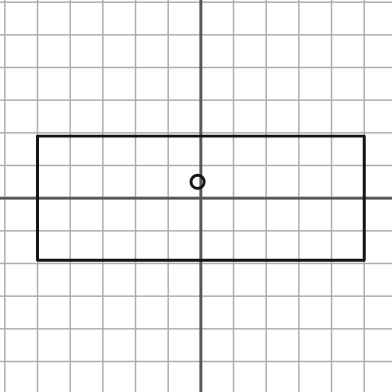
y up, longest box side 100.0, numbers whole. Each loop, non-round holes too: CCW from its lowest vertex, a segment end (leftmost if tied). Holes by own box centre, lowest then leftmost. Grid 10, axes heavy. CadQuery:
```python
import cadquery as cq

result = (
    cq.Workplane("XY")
    .moveTo(-50.0, -19.0)
    .lineTo(50.0, -19.0)
    .lineTo(50.0, 19.0)
    .lineTo(-50.0, 19.0)
    .close()
    .moveTo(-1.0, 5.0)
    .circle(2.0)
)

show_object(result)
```